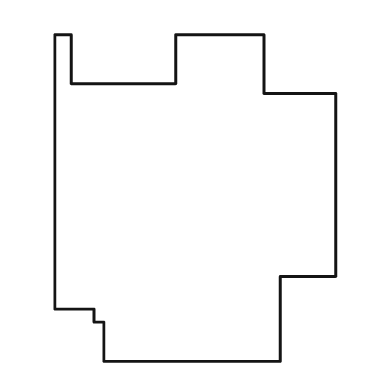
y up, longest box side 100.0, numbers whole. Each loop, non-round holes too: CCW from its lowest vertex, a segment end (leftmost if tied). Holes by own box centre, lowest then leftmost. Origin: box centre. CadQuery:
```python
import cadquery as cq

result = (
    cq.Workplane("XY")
    .moveTo(-28.0, -50.0)
    .lineTo(26.0, -50.0)
    .lineTo(26.0, -24.0)
    .lineTo(43.0, -24.0)
    .lineTo(43.0, 32.0)
    .lineTo(21.0, 32.0)
    .lineTo(21.0, 50.0)
    .lineTo(-6.0, 50.0)
    .lineTo(-6.0, 35.0)
    .lineTo(-38.0, 35.0)
    .lineTo(-38.0, 50.0)
    .lineTo(-43.0, 50.0)
    .lineTo(-43.0, -34.0)
    .lineTo(-31.0, -34.0)
    .lineTo(-31.0, -38.0)
    .lineTo(-28.0, -38.0)
    .close()
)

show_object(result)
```